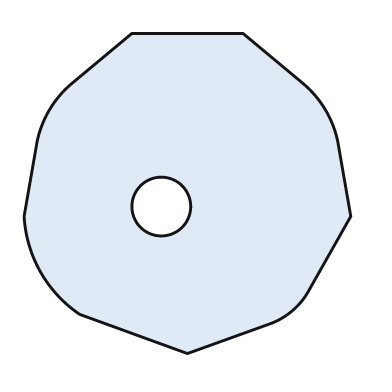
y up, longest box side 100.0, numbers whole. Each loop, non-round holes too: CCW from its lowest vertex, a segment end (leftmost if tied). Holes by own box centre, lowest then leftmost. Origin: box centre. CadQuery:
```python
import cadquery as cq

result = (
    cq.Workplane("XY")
    .moveTo(0.0, -49.0)
    .lineTo(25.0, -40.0)
    .threePointArc((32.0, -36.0), (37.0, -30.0))
    .lineTo(50.0, -7.0)
    .lineTo(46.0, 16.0)
    .threePointArc((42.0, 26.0), (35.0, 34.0))
    .lineTo(17.0, 49.0)
    .lineTo(-17.0, 49.0)
    .lineTo(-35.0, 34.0)
    .threePointArc((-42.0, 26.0), (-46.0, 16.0))
    .lineTo(-50.0, -7.0)
    .threePointArc((-45.0, -24.0), (-33.0, -37.0))
    .close()
    .moveTo(-8.0, -4.0)
    .circle(9.0)
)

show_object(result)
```